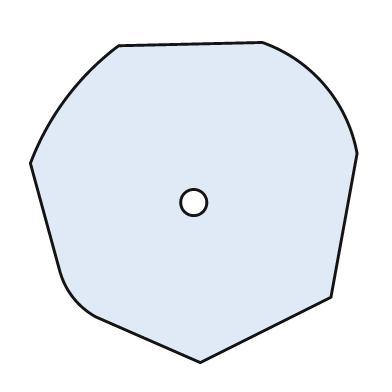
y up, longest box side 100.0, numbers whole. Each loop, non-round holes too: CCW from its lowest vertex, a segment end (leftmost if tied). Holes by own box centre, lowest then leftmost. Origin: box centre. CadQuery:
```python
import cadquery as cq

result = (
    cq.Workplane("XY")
    .moveTo(2.0, -49.0)
    .lineTo(42.0, -29.0)
    .lineTo(50.0, 15.0)
    .threePointArc((40.0, 36.0), (21.0, 49.0))
    .lineTo(-23.0, 48.0)
    .threePointArc((-39.0, 32.0), (-50.0, 12.0))
    .lineTo(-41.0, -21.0)
    .threePointArc((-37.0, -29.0), (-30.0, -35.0))
    .close()
    .moveTo(0.0, 0.0)
    .circle(4.0)
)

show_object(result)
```